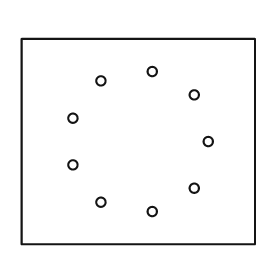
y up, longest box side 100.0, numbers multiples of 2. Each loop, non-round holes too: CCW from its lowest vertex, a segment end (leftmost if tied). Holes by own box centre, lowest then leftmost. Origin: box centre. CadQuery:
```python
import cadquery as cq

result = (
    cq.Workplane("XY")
    .moveTo(-50.0, -44.0)
    .lineTo(50.0, -44.0)
    .lineTo(50.0, 44.0)
    .lineTo(-50.0, 44.0)
    .close()
    .moveTo(6.0, -30.0)
    .circle(2.0)
    .moveTo(-16.0, -26.0)
    .circle(2.0)
    .moveTo(24.0, -20.0)
    .circle(2.0)
    .moveTo(-28.0, -10.0)
    .circle(2.0)
    .moveTo(30.0, 0.0)
    .circle(2.0)
    .moveTo(-28.0, 10.0)
    .circle(2.0)
    .moveTo(24.0, 20.0)
    .circle(2.0)
    .moveTo(-16.0, 26.0)
    .circle(2.0)
    .moveTo(6.0, 30.0)
    .circle(2.0)
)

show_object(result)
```